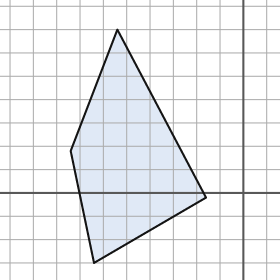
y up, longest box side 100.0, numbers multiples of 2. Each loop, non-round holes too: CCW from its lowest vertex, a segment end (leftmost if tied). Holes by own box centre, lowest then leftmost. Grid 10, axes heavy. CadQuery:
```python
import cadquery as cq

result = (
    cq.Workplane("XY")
    .moveTo(-64.0, -30.0)
    .lineTo(-16.0, -2.0)
    .lineTo(-54.0, 70.0)
    .lineTo(-74.0, 18.0)
    .close()
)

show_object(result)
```